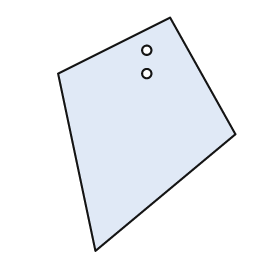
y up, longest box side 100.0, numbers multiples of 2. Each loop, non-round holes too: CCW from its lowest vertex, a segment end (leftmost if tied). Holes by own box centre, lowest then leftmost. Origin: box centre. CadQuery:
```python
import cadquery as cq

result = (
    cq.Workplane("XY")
    .moveTo(-22.0, -50.0)
    .lineTo(38.0, 0.0)
    .lineTo(10.0, 50.0)
    .lineTo(-38.0, 26.0)
    .close()
    .moveTo(0.0, 26.0)
    .circle(2.0)
    .moveTo(0.0, 36.0)
    .circle(2.0)
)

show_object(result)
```